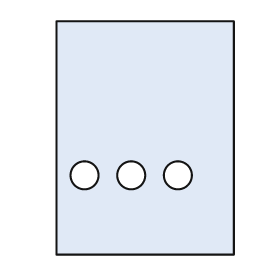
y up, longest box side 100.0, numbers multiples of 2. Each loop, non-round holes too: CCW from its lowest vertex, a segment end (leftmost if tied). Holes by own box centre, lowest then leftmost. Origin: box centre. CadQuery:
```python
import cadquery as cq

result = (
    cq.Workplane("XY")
    .moveTo(-38.0, -50.0)
    .lineTo(38.0, -50.0)
    .lineTo(38.0, 50.0)
    .lineTo(-38.0, 50.0)
    .close()
    .moveTo(-26.0, -16.0)
    .circle(6.0)
    .moveTo(-6.0, -16.0)
    .circle(6.0)
    .moveTo(14.0, -16.0)
    .circle(6.0)
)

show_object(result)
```